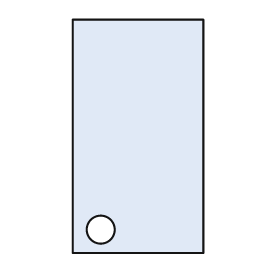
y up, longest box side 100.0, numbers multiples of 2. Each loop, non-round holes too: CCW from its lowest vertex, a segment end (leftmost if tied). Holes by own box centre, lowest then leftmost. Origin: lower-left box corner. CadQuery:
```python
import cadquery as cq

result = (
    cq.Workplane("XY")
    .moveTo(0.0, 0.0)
    .lineTo(56.0, 0.0)
    .lineTo(56.0, 100.0)
    .lineTo(0.0, 100.0)
    .close()
    .moveTo(12.0, 10.0)
    .circle(6.0)
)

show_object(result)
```